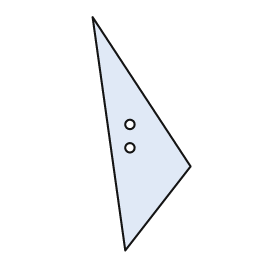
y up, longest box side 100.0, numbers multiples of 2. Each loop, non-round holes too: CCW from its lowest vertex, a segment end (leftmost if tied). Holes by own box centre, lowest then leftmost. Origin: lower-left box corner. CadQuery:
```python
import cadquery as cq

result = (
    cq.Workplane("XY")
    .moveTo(14.0, 0.0)
    .lineTo(42.0, 36.0)
    .lineTo(0.0, 100.0)
    .close()
    .moveTo(16.0, 44.0)
    .circle(2.0)
    .moveTo(16.0, 54.0)
    .circle(2.0)
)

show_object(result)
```